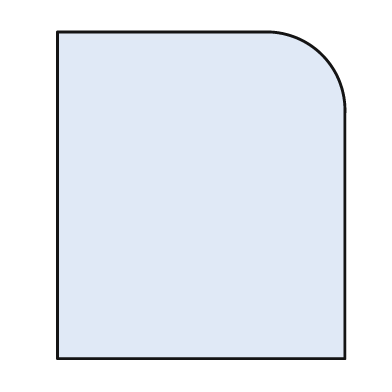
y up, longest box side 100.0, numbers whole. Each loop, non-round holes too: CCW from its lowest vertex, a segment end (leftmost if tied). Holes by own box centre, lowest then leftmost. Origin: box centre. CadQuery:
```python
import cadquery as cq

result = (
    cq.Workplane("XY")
    .moveTo(-44.0, -50.0)
    .lineTo(44.0, -50.0)
    .lineTo(44.0, 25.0)
    .threePointArc((37.0, 43.0), (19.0, 50.0))
    .lineTo(-44.0, 50.0)
    .close()
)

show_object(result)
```